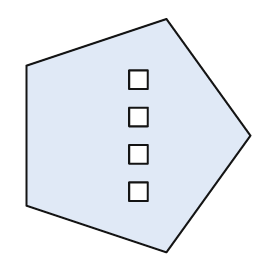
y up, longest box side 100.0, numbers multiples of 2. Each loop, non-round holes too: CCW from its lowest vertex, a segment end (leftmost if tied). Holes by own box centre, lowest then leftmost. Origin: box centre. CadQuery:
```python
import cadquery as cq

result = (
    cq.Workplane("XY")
    .moveTo(12.0, -50.0)
    .lineTo(48.0, 0.0)
    .lineTo(12.0, 50.0)
    .lineTo(-48.0, 30.0)
    .lineTo(-48.0, -30.0)
    .close()
    .moveTo(-4.0, -28.0)
    .lineTo(4.0, -28.0)
    .lineTo(4.0, -20.0)
    .lineTo(-4.0, -20.0)
    .close()
    .moveTo(-4.0, -12.0)
    .lineTo(4.0, -12.0)
    .lineTo(4.0, -4.0)
    .lineTo(-4.0, -4.0)
    .close()
    .moveTo(-4.0, 4.0)
    .lineTo(4.0, 4.0)
    .lineTo(4.0, 12.0)
    .lineTo(-4.0, 12.0)
    .close()
    .moveTo(-4.0, 20.0)
    .lineTo(4.0, 20.0)
    .lineTo(4.0, 28.0)
    .lineTo(-4.0, 28.0)
    .close()
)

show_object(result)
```